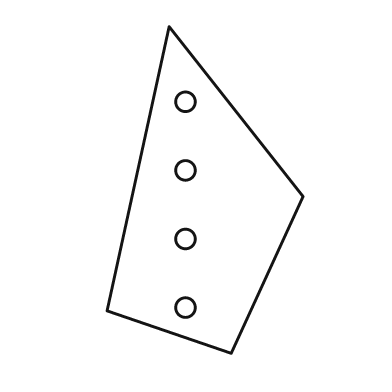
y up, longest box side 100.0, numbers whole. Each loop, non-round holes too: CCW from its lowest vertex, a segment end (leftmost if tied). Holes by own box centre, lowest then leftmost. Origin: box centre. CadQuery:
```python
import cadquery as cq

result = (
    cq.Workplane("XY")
    .moveTo(8.0, -50.0)
    .lineTo(30.0, -2.0)
    .lineTo(-11.0, 50.0)
    .lineTo(-30.0, -37.0)
    .close()
    .moveTo(-6.0, -36.0)
    .circle(3.0)
    .moveTo(-6.0, -15.0)
    .circle(3.0)
    .moveTo(-6.0, 6.0)
    .circle(3.0)
    .moveTo(-6.0, 27.0)
    .circle(3.0)
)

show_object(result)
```